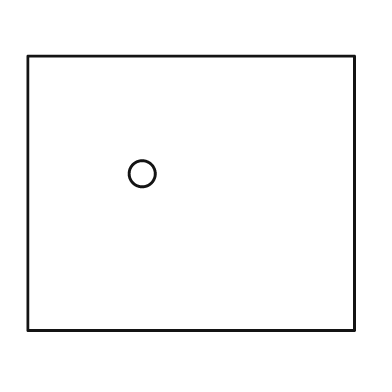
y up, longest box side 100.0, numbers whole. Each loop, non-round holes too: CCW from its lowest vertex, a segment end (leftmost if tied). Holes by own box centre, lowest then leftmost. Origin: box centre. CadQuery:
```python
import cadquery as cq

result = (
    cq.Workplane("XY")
    .moveTo(-50.0, -42.0)
    .lineTo(50.0, -42.0)
    .lineTo(50.0, 42.0)
    .lineTo(-50.0, 42.0)
    .close()
    .moveTo(-15.0, 6.0)
    .circle(4.0)
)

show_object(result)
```